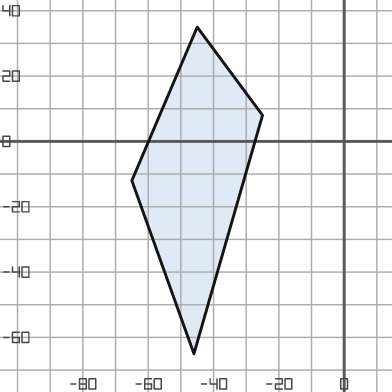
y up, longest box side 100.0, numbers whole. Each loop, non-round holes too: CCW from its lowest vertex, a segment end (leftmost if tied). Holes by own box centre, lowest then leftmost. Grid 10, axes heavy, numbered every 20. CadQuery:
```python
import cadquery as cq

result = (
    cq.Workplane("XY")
    .moveTo(-46.0, -65.0)
    .lineTo(-25.0, 8.0)
    .lineTo(-45.0, 35.0)
    .lineTo(-65.0, -12.0)
    .close()
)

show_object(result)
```